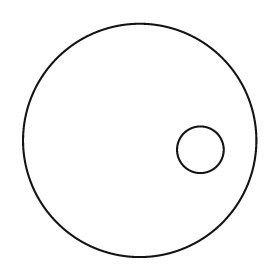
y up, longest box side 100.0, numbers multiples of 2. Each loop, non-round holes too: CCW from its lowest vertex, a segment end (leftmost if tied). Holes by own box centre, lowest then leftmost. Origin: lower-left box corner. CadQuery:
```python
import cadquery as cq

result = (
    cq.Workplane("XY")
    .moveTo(50.0, 50.0)
    .circle(50.0)
    .moveTo(76.0, 46.0)
    .circle(10.0)
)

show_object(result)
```